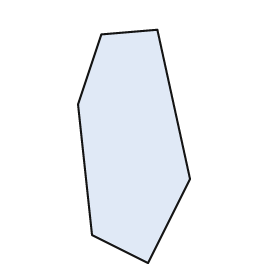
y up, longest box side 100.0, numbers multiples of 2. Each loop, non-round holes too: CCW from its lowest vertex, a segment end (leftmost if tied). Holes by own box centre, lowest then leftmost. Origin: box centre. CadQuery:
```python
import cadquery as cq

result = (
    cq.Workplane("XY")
    .moveTo(6.0, -50.0)
    .lineTo(24.0, -14.0)
    .lineTo(10.0, 50.0)
    .lineTo(-14.0, 48.0)
    .lineTo(-24.0, 18.0)
    .lineTo(-18.0, -38.0)
    .close()
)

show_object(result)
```